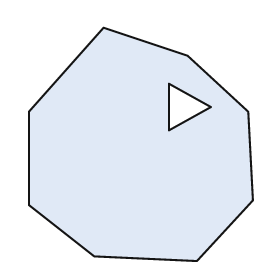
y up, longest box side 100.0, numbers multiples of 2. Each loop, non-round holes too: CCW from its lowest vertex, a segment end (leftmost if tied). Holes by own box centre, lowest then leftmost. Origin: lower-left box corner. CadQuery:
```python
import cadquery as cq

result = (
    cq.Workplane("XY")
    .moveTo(72.0, 0.0)
    .lineTo(96.0, 26.0)
    .lineTo(94.0, 64.0)
    .lineTo(68.0, 88.0)
    .lineTo(32.0, 100.0)
    .lineTo(0.0, 64.0)
    .lineTo(0.0, 24.0)
    .lineTo(28.0, 2.0)
    .close()
    .moveTo(60.0, 56.0)
    .lineTo(78.0, 66.0)
    .lineTo(60.0, 76.0)
    .close()
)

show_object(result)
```